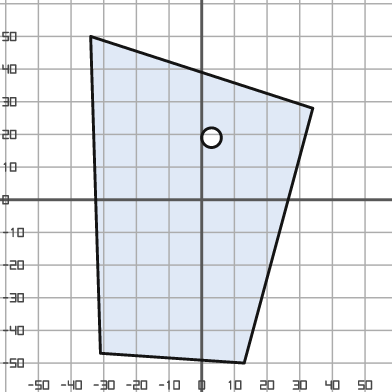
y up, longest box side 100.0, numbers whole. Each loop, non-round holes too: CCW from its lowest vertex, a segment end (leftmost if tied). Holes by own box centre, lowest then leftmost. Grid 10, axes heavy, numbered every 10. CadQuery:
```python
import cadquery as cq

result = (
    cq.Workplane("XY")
    .moveTo(13.0, -50.0)
    .lineTo(34.0, 28.0)
    .lineTo(-34.0, 50.0)
    .lineTo(-31.0, -47.0)
    .close()
    .moveTo(3.0, 19.0)
    .circle(3.0)
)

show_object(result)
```